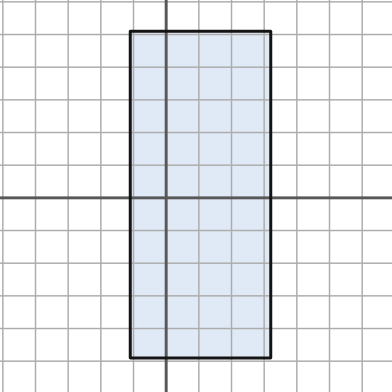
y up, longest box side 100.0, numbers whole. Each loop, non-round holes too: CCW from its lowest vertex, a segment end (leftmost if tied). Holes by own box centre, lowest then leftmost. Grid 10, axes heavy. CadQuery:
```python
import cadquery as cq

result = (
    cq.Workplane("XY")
    .moveTo(-11.0, -49.0)
    .lineTo(32.0, -49.0)
    .lineTo(32.0, 51.0)
    .lineTo(-11.0, 51.0)
    .close()
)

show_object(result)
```